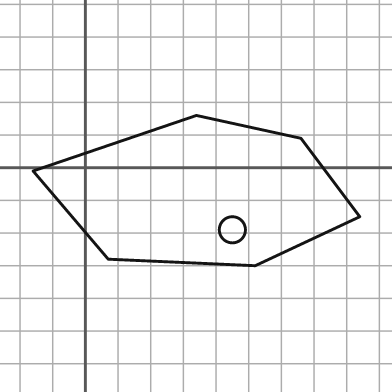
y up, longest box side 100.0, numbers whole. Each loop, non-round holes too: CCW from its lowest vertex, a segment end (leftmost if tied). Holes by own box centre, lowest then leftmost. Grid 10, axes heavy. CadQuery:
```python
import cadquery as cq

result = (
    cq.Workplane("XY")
    .moveTo(52.0, -30.0)
    .lineTo(84.0, -15.0)
    .lineTo(66.0, 9.0)
    .lineTo(34.0, 16.0)
    .lineTo(-16.0, -1.0)
    .lineTo(7.0, -28.0)
    .close()
    .moveTo(45.0, -19.0)
    .circle(4.0)
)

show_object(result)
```